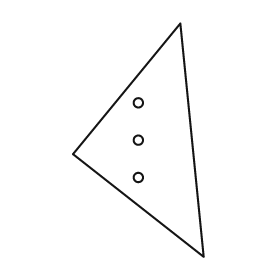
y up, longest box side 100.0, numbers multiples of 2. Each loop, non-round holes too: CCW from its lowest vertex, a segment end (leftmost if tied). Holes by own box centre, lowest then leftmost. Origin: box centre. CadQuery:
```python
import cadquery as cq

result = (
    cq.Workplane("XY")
    .moveTo(28.0, -50.0)
    .lineTo(18.0, 50.0)
    .lineTo(-28.0, -6.0)
    .close()
    .moveTo(0.0, -16.0)
    .circle(2.0)
    .moveTo(0.0, 0.0)
    .circle(2.0)
    .moveTo(0.0, 16.0)
    .circle(2.0)
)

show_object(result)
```